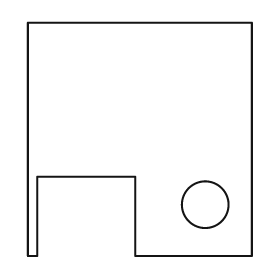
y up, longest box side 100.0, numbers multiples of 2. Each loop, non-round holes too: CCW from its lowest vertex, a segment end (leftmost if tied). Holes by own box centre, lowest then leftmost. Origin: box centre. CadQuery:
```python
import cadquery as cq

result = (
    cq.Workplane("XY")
    .moveTo(-48.0, -50.0)
    .lineTo(-44.0, -50.0)
    .lineTo(-44.0, -16.0)
    .lineTo(-2.0, -16.0)
    .lineTo(-2.0, -50.0)
    .lineTo(48.0, -50.0)
    .lineTo(48.0, 50.0)
    .lineTo(-48.0, 50.0)
    .close()
    .moveTo(28.0, -28.0)
    .circle(10.0)
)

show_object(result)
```